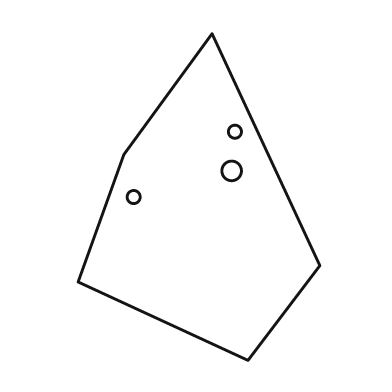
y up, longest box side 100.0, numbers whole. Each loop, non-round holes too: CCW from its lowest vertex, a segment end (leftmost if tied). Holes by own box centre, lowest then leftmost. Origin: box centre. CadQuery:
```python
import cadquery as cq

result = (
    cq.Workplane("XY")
    .moveTo(15.0, -50.0)
    .lineTo(37.0, -21.0)
    .lineTo(4.0, 50.0)
    .lineTo(-23.0, 13.0)
    .lineTo(-37.0, -26.0)
    .close()
    .moveTo(-20.0, 0.0)
    .circle(2.0)
    .moveTo(10.0, 8.0)
    .circle(3.0)
    .moveTo(11.0, 20.0)
    .circle(2.0)
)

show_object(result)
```